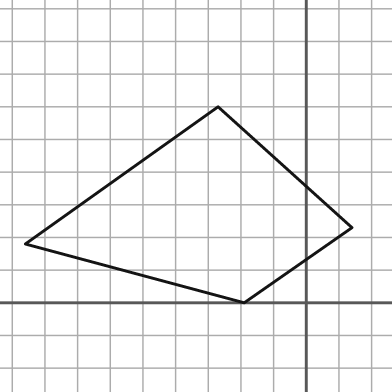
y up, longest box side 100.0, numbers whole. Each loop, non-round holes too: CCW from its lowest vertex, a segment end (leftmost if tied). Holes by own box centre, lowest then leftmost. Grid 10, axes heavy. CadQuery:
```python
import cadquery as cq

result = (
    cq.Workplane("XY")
    .moveTo(-19.0, 0.0)
    .lineTo(14.0, 23.0)
    .lineTo(-27.0, 60.0)
    .lineTo(-86.0, 18.0)
    .close()
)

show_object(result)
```